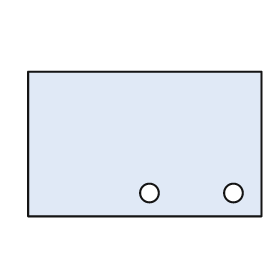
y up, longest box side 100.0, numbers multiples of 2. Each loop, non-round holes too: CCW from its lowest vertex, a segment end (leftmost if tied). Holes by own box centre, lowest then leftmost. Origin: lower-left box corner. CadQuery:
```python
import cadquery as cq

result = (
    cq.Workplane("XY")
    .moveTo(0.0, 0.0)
    .lineTo(100.0, 0.0)
    .lineTo(100.0, 62.0)
    .lineTo(0.0, 62.0)
    .close()
    .moveTo(52.0, 10.0)
    .circle(4.0)
    .moveTo(88.0, 10.0)
    .circle(4.0)
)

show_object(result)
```